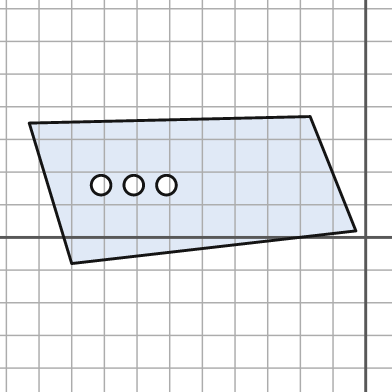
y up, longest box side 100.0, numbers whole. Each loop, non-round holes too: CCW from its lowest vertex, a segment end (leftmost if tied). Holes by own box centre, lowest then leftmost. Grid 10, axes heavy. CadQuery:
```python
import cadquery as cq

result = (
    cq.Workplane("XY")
    .moveTo(-90.0, -8.0)
    .lineTo(-3.0, 2.0)
    .lineTo(-17.0, 37.0)
    .lineTo(-103.0, 35.0)
    .close()
    .moveTo(-81.0, 16.0)
    .circle(3.0)
    .moveTo(-71.0, 16.0)
    .circle(3.0)
    .moveTo(-61.0, 16.0)
    .circle(3.0)
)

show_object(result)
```